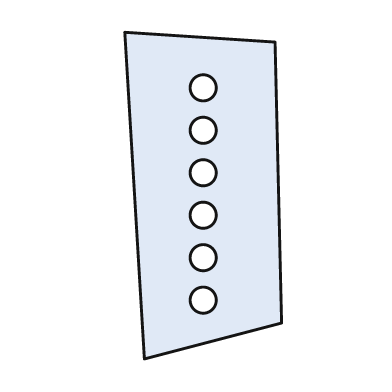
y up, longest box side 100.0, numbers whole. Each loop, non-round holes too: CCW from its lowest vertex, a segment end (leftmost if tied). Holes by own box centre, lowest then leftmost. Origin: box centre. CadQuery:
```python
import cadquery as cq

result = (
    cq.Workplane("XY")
    .moveTo(-18.0, -50.0)
    .lineTo(24.0, -39.0)
    .lineTo(22.0, 47.0)
    .lineTo(-24.0, 50.0)
    .close()
    .moveTo(0.0, -32.0)
    .circle(4.0)
    .moveTo(0.0, -19.0)
    .circle(4.0)
    .moveTo(0.0, -6.0)
    .circle(4.0)
    .moveTo(0.0, 7.0)
    .circle(4.0)
    .moveTo(0.0, 20.0)
    .circle(4.0)
    .moveTo(0.0, 33.0)
    .circle(4.0)
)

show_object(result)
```